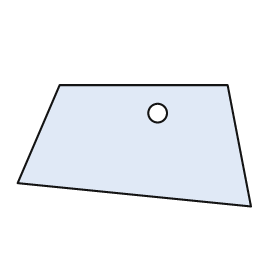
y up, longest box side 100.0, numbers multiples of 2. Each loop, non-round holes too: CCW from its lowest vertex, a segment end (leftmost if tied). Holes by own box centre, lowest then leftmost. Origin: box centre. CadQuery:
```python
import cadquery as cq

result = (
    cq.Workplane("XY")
    .moveTo(50.0, -26.0)
    .lineTo(40.0, 26.0)
    .lineTo(-32.0, 26.0)
    .lineTo(-50.0, -16.0)
    .close()
    .moveTo(10.0, 14.0)
    .circle(4.0)
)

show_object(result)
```